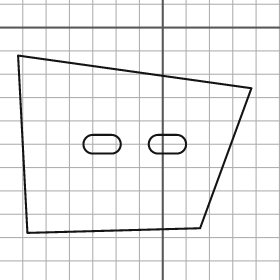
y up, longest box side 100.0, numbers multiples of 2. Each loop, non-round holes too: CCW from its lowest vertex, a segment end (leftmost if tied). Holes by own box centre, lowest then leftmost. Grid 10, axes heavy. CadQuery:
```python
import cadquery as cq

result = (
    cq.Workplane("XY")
    .moveTo(-58.0, -88.0)
    .lineTo(16.0, -86.0)
    .lineTo(38.0, -26.0)
    .lineTo(-62.0, -12.0)
    .close()
    .moveTo(-30.0, -54.0)
    .lineTo(-22.0, -54.0)
    .threePointArc((-18.0, -50.0), (-22.0, -46.0))
    .lineTo(-30.0, -46.0)
    .threePointArc((-34.0, -50.0), (-30.0, -54.0))
    .close()
    .moveTo(-2.0, -54.0)
    .lineTo(6.0, -54.0)
    .threePointArc((10.0, -50.0), (6.0, -46.0))
    .lineTo(-2.0, -46.0)
    .threePointArc((-6.0, -50.0), (-2.0, -54.0))
    .close()
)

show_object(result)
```